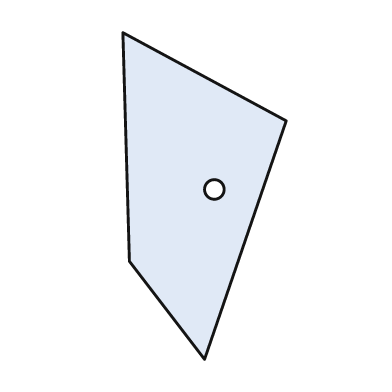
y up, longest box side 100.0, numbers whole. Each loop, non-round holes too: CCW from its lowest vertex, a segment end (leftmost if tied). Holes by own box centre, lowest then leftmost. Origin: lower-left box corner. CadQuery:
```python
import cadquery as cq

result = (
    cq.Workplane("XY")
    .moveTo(25.0, 0.0)
    .lineTo(50.0, 73.0)
    .lineTo(0.0, 100.0)
    .lineTo(2.0, 30.0)
    .close()
    .moveTo(28.0, 52.0)
    .circle(3.0)
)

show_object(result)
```